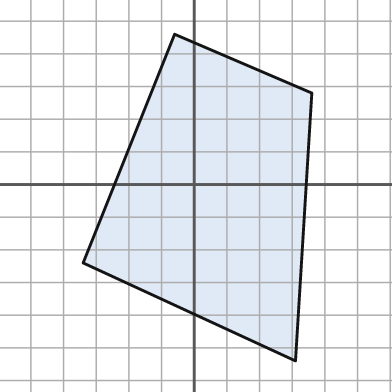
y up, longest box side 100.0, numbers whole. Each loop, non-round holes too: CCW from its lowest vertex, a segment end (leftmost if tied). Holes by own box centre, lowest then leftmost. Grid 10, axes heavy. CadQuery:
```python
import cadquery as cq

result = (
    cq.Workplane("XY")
    .moveTo(31.0, -54.0)
    .lineTo(36.0, 28.0)
    .lineTo(-6.0, 46.0)
    .lineTo(-34.0, -24.0)
    .close()
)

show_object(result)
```